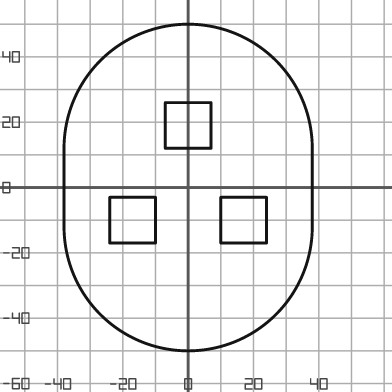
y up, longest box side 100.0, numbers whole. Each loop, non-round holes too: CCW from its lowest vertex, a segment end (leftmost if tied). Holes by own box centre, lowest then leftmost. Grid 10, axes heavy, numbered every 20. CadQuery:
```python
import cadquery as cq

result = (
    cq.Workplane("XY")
    .moveTo(-38.0, -12.0)
    .threePointArc((0.0, -50.0), (38.0, -12.0))
    .lineTo(38.0, 12.0)
    .threePointArc((0.0, 50.0), (-38.0, 12.0))
    .close()
    .moveTo(-24.0, -17.0)
    .lineTo(-10.0, -17.0)
    .lineTo(-10.0, -3.0)
    .lineTo(-24.0, -3.0)
    .close()
    .moveTo(10.0, -17.0)
    .lineTo(24.0, -17.0)
    .lineTo(24.0, -3.0)
    .lineTo(10.0, -3.0)
    .close()
    .moveTo(-7.0, 12.0)
    .lineTo(7.0, 12.0)
    .lineTo(7.0, 26.0)
    .lineTo(-7.0, 26.0)
    .close()
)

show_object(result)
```